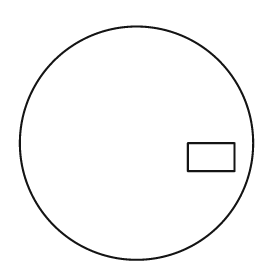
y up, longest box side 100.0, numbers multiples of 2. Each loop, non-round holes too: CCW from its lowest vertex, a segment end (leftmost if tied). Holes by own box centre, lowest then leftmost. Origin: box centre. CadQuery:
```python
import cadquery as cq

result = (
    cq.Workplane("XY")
    .moveTo(0.0, 0.0)
    .circle(50.0)
    .moveTo(22.0, -12.0)
    .lineTo(42.0, -12.0)
    .lineTo(42.0, 0.0)
    .lineTo(22.0, 0.0)
    .close()
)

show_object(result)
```